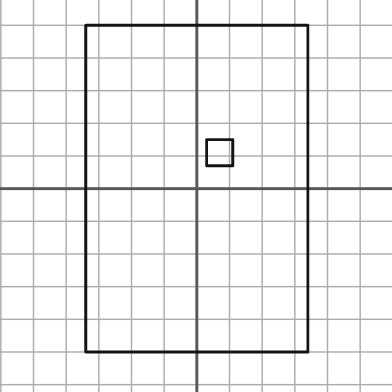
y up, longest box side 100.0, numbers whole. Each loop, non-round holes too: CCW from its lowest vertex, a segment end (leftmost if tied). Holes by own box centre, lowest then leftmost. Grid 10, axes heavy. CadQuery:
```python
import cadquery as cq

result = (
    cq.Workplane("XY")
    .moveTo(-34.0, -50.0)
    .lineTo(34.0, -50.0)
    .lineTo(34.0, 50.0)
    .lineTo(-34.0, 50.0)
    .close()
    .moveTo(3.0, 7.0)
    .lineTo(11.0, 7.0)
    .lineTo(11.0, 15.0)
    .lineTo(3.0, 15.0)
    .close()
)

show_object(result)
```